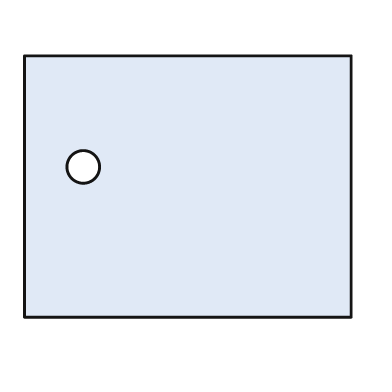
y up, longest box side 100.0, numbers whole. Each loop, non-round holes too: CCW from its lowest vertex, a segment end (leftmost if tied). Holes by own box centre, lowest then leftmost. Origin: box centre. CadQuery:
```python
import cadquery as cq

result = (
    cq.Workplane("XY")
    .moveTo(-50.0, -40.0)
    .lineTo(50.0, -40.0)
    .lineTo(50.0, 40.0)
    .lineTo(-50.0, 40.0)
    .close()
    .moveTo(-32.0, 6.0)
    .circle(5.0)
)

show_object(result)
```